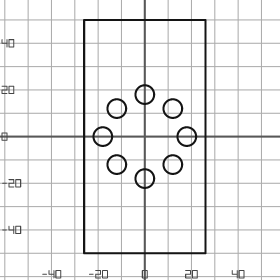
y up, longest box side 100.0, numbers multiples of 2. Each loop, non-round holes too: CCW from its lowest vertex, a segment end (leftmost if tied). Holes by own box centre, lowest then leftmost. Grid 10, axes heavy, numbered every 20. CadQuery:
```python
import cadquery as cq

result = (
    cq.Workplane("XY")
    .moveTo(-26.0, -50.0)
    .lineTo(26.0, -50.0)
    .lineTo(26.0, 50.0)
    .lineTo(-26.0, 50.0)
    .close()
    .moveTo(0.0, -18.0)
    .circle(4.0)
    .moveTo(-12.0, -12.0)
    .circle(4.0)
    .moveTo(12.0, -12.0)
    .circle(4.0)
    .moveTo(-18.0, 0.0)
    .circle(4.0)
    .moveTo(18.0, 0.0)
    .circle(4.0)
    .moveTo(-12.0, 12.0)
    .circle(4.0)
    .moveTo(12.0, 12.0)
    .circle(4.0)
    .moveTo(0.0, 18.0)
    .circle(4.0)
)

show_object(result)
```